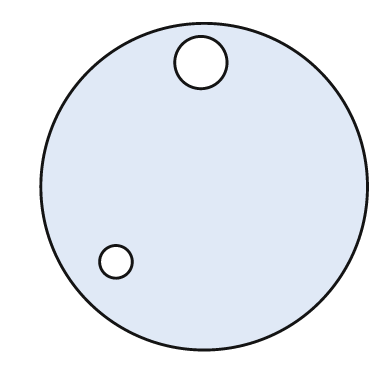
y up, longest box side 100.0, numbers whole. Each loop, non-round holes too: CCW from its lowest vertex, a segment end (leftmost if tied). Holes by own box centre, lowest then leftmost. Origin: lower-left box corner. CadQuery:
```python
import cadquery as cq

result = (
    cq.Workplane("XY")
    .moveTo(50.0, 50.0)
    .circle(50.0)
    .moveTo(23.0, 27.0)
    .circle(5.0)
    .moveTo(49.0, 88.0)
    .circle(8.0)
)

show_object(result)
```